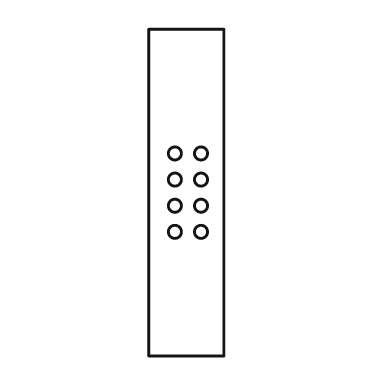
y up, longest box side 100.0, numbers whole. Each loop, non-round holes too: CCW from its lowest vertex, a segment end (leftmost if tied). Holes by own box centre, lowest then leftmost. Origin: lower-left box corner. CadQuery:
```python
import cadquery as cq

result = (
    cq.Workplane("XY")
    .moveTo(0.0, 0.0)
    .lineTo(23.0, 0.0)
    .lineTo(23.0, 100.0)
    .lineTo(0.0, 100.0)
    .close()
    .moveTo(8.0, 38.0)
    .circle(2.0)
    .moveTo(16.0, 38.0)
    .circle(2.0)
    .moveTo(8.0, 46.0)
    .circle(2.0)
    .moveTo(16.0, 46.0)
    .circle(2.0)
    .moveTo(8.0, 54.0)
    .circle(2.0)
    .moveTo(16.0, 54.0)
    .circle(2.0)
    .moveTo(8.0, 62.0)
    .circle(2.0)
    .moveTo(16.0, 62.0)
    .circle(2.0)
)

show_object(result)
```